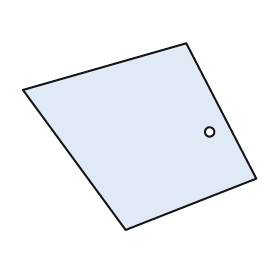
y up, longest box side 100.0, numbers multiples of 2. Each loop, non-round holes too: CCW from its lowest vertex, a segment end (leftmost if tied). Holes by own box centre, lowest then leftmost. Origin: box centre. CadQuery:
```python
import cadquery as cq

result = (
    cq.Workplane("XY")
    .moveTo(-6.0, -40.0)
    .lineTo(50.0, -18.0)
    .lineTo(20.0, 40.0)
    .lineTo(-50.0, 20.0)
    .close()
    .moveTo(30.0, 2.0)
    .circle(2.0)
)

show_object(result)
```